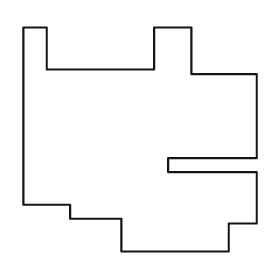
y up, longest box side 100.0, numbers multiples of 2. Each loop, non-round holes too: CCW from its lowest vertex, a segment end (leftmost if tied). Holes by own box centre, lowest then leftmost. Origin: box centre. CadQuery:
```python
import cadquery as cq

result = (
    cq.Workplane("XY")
    .moveTo(-8.0, -48.0)
    .lineTo(38.0, -48.0)
    .lineTo(38.0, -36.0)
    .lineTo(50.0, -36.0)
    .lineTo(50.0, -14.0)
    .lineTo(12.0, -14.0)
    .lineTo(12.0, -8.0)
    .lineTo(50.0, -8.0)
    .lineTo(50.0, 28.0)
    .lineTo(22.0, 28.0)
    .lineTo(22.0, 48.0)
    .lineTo(6.0, 48.0)
    .lineTo(6.0, 30.0)
    .lineTo(-40.0, 30.0)
    .lineTo(-40.0, 48.0)
    .lineTo(-50.0, 48.0)
    .lineTo(-50.0, -28.0)
    .lineTo(-30.0, -28.0)
    .lineTo(-30.0, -34.0)
    .lineTo(-8.0, -34.0)
    .close()
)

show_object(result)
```